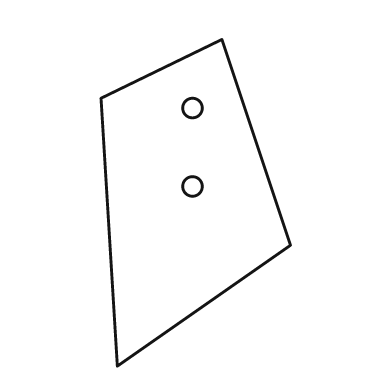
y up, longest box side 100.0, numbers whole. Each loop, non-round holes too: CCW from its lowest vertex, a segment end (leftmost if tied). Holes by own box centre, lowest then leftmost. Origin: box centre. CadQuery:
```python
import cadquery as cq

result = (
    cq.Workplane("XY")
    .moveTo(-24.0, -50.0)
    .lineTo(29.0, -13.0)
    .lineTo(8.0, 50.0)
    .lineTo(-29.0, 32.0)
    .close()
    .moveTo(-1.0, 5.0)
    .circle(3.0)
    .moveTo(-1.0, 29.0)
    .circle(3.0)
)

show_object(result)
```